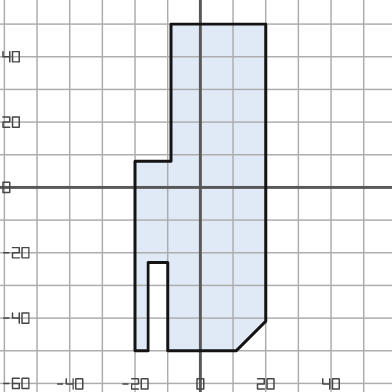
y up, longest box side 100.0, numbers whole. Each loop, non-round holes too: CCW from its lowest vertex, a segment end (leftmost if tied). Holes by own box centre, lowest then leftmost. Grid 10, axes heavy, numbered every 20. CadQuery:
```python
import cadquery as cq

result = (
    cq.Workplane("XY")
    .moveTo(-20.0, -50.0)
    .lineTo(-16.0, -50.0)
    .lineTo(-16.0, -23.0)
    .lineTo(-10.0, -23.0)
    .lineTo(-10.0, -50.0)
    .lineTo(11.0, -50.0)
    .lineTo(20.0, -41.0)
    .lineTo(20.0, 50.0)
    .lineTo(-9.0, 50.0)
    .lineTo(-9.0, 8.0)
    .lineTo(-20.0, 8.0)
    .close()
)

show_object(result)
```